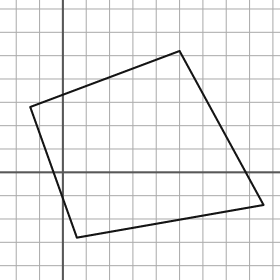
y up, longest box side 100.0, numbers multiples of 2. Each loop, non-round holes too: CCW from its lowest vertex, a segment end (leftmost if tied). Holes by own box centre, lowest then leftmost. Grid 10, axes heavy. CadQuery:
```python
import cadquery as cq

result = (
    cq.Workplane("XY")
    .moveTo(6.0, -28.0)
    .lineTo(86.0, -14.0)
    .lineTo(50.0, 52.0)
    .lineTo(-14.0, 28.0)
    .close()
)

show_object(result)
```